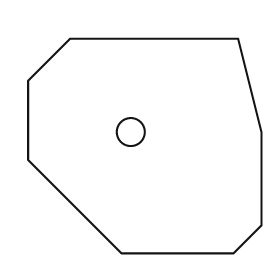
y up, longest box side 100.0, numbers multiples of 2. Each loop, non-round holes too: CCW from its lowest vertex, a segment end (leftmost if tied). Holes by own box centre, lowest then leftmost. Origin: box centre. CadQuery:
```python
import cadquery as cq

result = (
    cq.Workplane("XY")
    .moveTo(-10.0, -46.0)
    .lineTo(38.0, -46.0)
    .lineTo(50.0, -34.0)
    .lineTo(50.0, 6.0)
    .lineTo(40.0, 46.0)
    .lineTo(-32.0, 46.0)
    .lineTo(-50.0, 28.0)
    .lineTo(-50.0, -6.0)
    .close()
    .moveTo(-6.0, 6.0)
    .circle(6.0)
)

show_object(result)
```